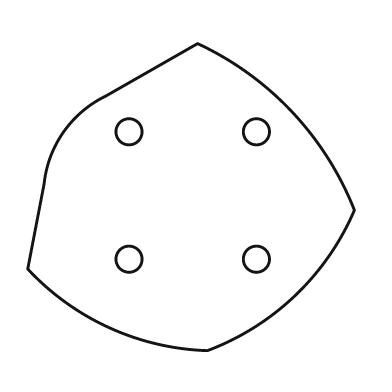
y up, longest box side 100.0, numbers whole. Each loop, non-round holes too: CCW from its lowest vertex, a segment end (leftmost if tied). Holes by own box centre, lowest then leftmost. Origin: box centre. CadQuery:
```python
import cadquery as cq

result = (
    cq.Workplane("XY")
    .moveTo(5.0, -47.0)
    .threePointArc((32.0, -30.0), (50.0, -4.0))
    .threePointArc((31.0, 26.0), (2.0, 47.0))
    .lineTo(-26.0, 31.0)
    .threePointArc((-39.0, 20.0), (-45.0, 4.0))
    .lineTo(-50.0, -22.0)
    .threePointArc((-25.0, -40.0), (5.0, -47.0))
    .close()
    .moveTo(-19.0, -19.0)
    .circle(4.0)
    .moveTo(20.0, -19.0)
    .circle(4.0)
    .moveTo(-19.0, 20.0)
    .circle(4.0)
    .moveTo(20.0, 20.0)
    .circle(4.0)
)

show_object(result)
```